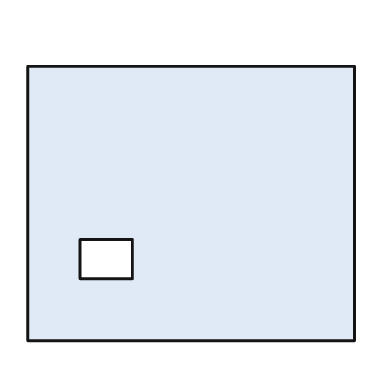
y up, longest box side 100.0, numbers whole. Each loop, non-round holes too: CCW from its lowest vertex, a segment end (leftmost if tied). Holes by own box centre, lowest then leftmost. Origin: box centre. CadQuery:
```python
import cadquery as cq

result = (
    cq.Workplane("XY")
    .moveTo(-50.0, -42.0)
    .lineTo(50.0, -42.0)
    .lineTo(50.0, 42.0)
    .lineTo(-50.0, 42.0)
    .close()
    .moveTo(-34.0, -23.0)
    .lineTo(-18.0, -23.0)
    .lineTo(-18.0, -11.0)
    .lineTo(-34.0, -11.0)
    .close()
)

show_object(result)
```